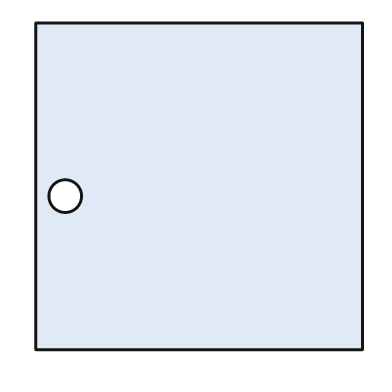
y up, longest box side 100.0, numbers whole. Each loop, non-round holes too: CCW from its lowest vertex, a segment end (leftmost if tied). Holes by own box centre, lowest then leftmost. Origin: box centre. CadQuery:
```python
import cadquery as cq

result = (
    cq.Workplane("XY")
    .moveTo(-50.0, -50.0)
    .lineTo(50.0, -50.0)
    .lineTo(50.0, 50.0)
    .lineTo(-50.0, 50.0)
    .close()
    .moveTo(-41.0, -3.0)
    .circle(5.0)
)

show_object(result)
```